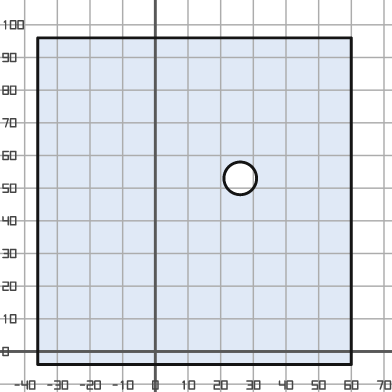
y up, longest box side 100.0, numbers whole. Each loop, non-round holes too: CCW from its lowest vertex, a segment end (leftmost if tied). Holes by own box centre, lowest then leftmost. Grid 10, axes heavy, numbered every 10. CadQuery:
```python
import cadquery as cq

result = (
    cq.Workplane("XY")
    .moveTo(-36.0, -4.0)
    .lineTo(60.0, -4.0)
    .lineTo(60.0, 96.0)
    .lineTo(-36.0, 96.0)
    .close()
    .moveTo(26.0, 53.0)
    .circle(5.0)
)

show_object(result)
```